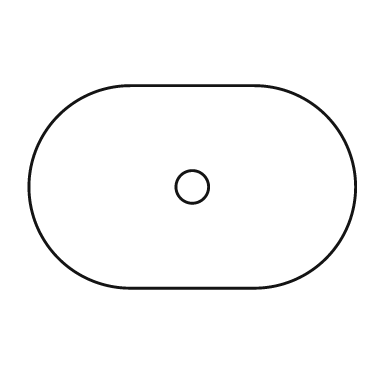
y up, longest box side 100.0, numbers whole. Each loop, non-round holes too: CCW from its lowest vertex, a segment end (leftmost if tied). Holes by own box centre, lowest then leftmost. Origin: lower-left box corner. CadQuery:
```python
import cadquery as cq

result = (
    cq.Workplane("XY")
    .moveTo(31.0, 0.0)
    .lineTo(69.0, 0.0)
    .threePointArc((100.0, 31.0), (69.0, 62.0))
    .lineTo(31.0, 62.0)
    .threePointArc((0.0, 31.0), (31.0, 0.0))
    .close()
    .moveTo(50.0, 31.0)
    .circle(5.0)
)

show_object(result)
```